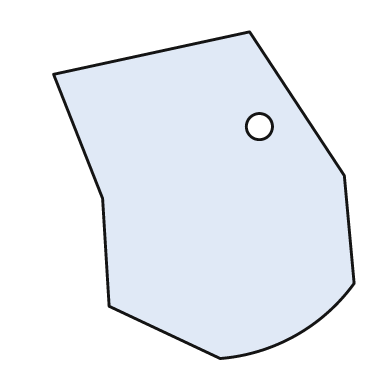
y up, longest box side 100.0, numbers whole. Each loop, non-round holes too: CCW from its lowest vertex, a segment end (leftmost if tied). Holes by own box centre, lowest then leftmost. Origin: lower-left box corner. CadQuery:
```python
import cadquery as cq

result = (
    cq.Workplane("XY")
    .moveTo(51.0, 0.0)
    .threePointArc((74.0, 7.0), (92.0, 23.0))
    .lineTo(89.0, 56.0)
    .lineTo(60.0, 100.0)
    .lineTo(0.0, 87.0)
    .lineTo(15.0, 49.0)
    .lineTo(17.0, 16.0)
    .close()
    .moveTo(63.0, 71.0)
    .circle(4.0)
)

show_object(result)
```